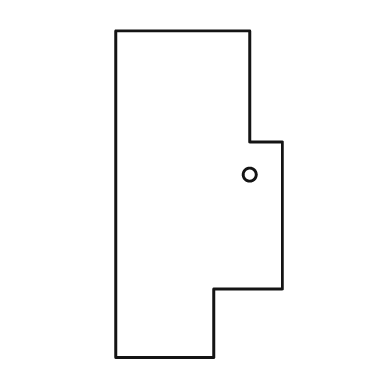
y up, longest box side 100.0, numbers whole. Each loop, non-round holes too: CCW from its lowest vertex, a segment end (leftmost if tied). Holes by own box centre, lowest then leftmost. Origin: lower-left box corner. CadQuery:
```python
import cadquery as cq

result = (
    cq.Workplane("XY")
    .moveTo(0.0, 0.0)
    .lineTo(30.0, 0.0)
    .lineTo(30.0, 21.0)
    .lineTo(51.0, 21.0)
    .lineTo(51.0, 66.0)
    .lineTo(41.0, 66.0)
    .lineTo(41.0, 100.0)
    .lineTo(0.0, 100.0)
    .close()
    .moveTo(41.0, 56.0)
    .circle(2.0)
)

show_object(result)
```